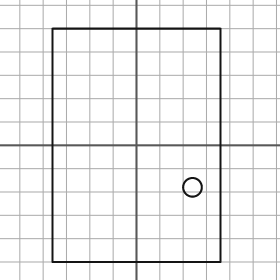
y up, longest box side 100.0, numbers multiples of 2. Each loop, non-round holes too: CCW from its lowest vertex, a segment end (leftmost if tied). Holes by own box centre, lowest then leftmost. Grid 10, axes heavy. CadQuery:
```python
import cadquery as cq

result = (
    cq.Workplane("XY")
    .moveTo(-36.0, -50.0)
    .lineTo(36.0, -50.0)
    .lineTo(36.0, 50.0)
    .lineTo(-36.0, 50.0)
    .close()
    .moveTo(24.0, -18.0)
    .circle(4.0)
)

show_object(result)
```